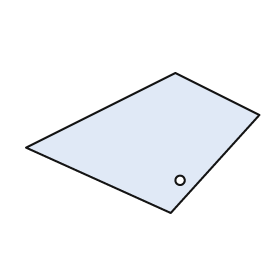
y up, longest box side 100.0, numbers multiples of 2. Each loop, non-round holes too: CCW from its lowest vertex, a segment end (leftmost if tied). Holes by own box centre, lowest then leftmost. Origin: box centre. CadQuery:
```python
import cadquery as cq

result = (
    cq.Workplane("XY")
    .moveTo(12.0, -30.0)
    .lineTo(50.0, 12.0)
    .lineTo(14.0, 30.0)
    .lineTo(-50.0, -2.0)
    .close()
    .moveTo(16.0, -16.0)
    .circle(2.0)
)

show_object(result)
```